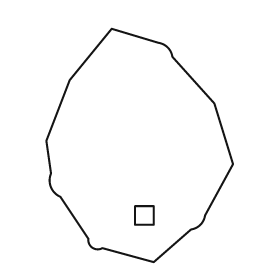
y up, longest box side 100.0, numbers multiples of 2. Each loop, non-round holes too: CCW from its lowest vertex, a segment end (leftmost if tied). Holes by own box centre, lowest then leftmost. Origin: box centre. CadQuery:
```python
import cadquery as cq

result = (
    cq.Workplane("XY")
    .moveTo(6.0, -50.0)
    .lineTo(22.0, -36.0)
    .threePointArc((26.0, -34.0), (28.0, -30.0))
    .lineTo(40.0, -8.0)
    .lineTo(32.0, 18.0)
    .lineTo(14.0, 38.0)
    .threePointArc((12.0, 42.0), (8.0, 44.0))
    .lineTo(-12.0, 50.0)
    .lineTo(-30.0, 28.0)
    .lineTo(-40.0, 2.0)
    .lineTo(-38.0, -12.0)
    .threePointArc((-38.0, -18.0), (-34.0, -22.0))
    .lineTo(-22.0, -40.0)
    .threePointArc((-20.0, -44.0), (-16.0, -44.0))
    .close()
    .moveTo(-2.0, -34.0)
    .lineTo(6.0, -34.0)
    .lineTo(6.0, -26.0)
    .lineTo(-2.0, -26.0)
    .close()
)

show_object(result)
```